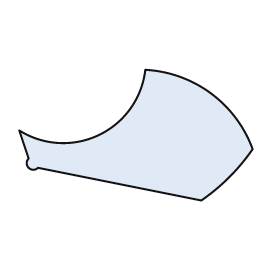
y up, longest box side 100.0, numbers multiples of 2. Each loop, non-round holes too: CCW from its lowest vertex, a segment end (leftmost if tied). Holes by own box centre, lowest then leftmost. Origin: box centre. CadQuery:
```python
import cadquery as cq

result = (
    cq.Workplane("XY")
    .moveTo(28.0, -28.0)
    .threePointArc((40.0, -18.0), (50.0, -6.0))
    .threePointArc((32.0, 18.0), (4.0, 28.0))
    .threePointArc((-16.0, 0.0), (-50.0, 2.0))
    .lineTo(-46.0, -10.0)
    .threePointArc((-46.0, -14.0), (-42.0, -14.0))
    .close()
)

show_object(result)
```